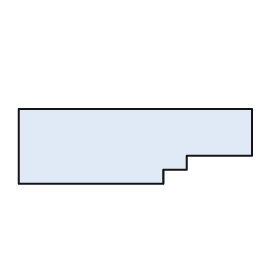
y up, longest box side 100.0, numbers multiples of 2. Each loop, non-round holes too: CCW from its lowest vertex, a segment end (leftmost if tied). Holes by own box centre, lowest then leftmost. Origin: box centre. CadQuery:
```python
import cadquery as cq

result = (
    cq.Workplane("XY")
    .moveTo(-50.0, -16.0)
    .lineTo(12.0, -16.0)
    .lineTo(12.0, -10.0)
    .lineTo(22.0, -10.0)
    .lineTo(22.0, -4.0)
    .lineTo(50.0, -4.0)
    .lineTo(50.0, 16.0)
    .lineTo(-50.0, 16.0)
    .close()
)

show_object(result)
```